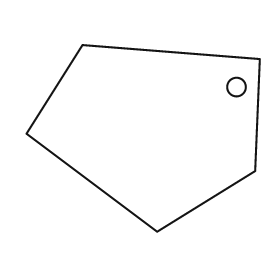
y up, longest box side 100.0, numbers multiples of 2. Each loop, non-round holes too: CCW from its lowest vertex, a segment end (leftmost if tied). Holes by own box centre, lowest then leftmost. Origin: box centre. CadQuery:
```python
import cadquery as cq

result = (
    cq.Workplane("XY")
    .moveTo(6.0, -40.0)
    .lineTo(48.0, -14.0)
    .lineTo(50.0, 34.0)
    .lineTo(-26.0, 40.0)
    .lineTo(-50.0, 2.0)
    .close()
    .moveTo(40.0, 22.0)
    .circle(4.0)
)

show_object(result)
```